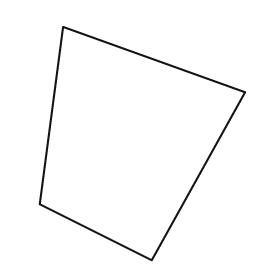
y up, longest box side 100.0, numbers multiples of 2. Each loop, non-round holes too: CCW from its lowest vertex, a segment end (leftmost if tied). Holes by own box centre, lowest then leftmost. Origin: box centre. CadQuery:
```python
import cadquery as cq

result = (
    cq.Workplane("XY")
    .moveTo(4.0, -50.0)
    .lineTo(44.0, 22.0)
    .lineTo(-34.0, 50.0)
    .lineTo(-44.0, -26.0)
    .close()
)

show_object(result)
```